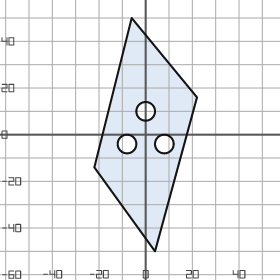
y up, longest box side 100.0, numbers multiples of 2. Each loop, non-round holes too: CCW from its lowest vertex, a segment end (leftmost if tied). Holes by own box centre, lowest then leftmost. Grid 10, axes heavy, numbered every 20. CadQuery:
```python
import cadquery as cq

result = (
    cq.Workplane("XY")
    .moveTo(4.0, -50.0)
    .lineTo(22.0, 16.0)
    .lineTo(-6.0, 50.0)
    .lineTo(-22.0, -14.0)
    .close()
    .moveTo(-8.0, -4.0)
    .circle(4.0)
    .moveTo(8.0, -4.0)
    .circle(4.0)
    .moveTo(0.0, 10.0)
    .circle(4.0)
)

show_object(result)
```